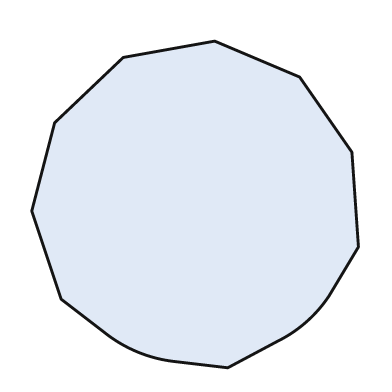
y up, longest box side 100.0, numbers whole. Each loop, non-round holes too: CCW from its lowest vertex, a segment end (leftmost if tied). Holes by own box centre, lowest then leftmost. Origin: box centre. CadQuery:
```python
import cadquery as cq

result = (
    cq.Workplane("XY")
    .moveTo(10.0, -50.0)
    .lineTo(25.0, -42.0)
    .threePointArc((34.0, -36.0), (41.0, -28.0))
    .lineTo(50.0, -13.0)
    .lineTo(48.0, 16.0)
    .lineTo(32.0, 39.0)
    .lineTo(6.0, 50.0)
    .lineTo(-22.0, 45.0)
    .lineTo(-43.0, 25.0)
    .lineTo(-50.0, -2.0)
    .lineTo(-41.0, -29.0)
    .lineTo(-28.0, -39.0)
    .threePointArc((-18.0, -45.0), (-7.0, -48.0))
    .close()
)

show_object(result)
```